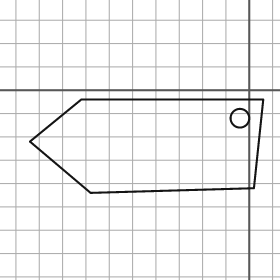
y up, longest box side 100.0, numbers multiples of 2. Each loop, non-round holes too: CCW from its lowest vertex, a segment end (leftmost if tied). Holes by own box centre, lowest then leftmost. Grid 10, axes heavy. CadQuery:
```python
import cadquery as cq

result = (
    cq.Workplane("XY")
    .moveTo(-68.0, -44.0)
    .lineTo(2.0, -42.0)
    .lineTo(6.0, -4.0)
    .lineTo(-72.0, -4.0)
    .lineTo(-94.0, -22.0)
    .close()
    .moveTo(-4.0, -12.0)
    .circle(4.0)
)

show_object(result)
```